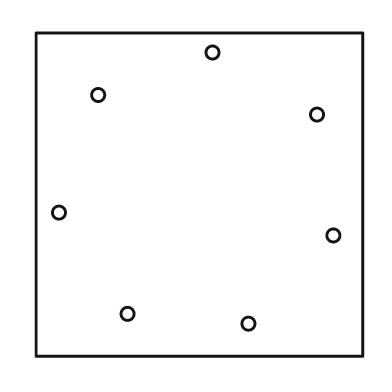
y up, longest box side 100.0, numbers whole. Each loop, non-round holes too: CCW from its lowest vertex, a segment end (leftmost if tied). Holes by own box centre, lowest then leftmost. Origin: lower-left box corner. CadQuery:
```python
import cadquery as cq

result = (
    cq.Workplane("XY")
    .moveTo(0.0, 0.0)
    .lineTo(100.0, 0.0)
    .lineTo(100.0, 99.0)
    .lineTo(0.0, 99.0)
    .close()
    .moveTo(65.0, 10.0)
    .circle(2.0)
    .moveTo(28.0, 13.0)
    .circle(2.0)
    .moveTo(91.0, 37.0)
    .circle(2.0)
    .moveTo(7.0, 44.0)
    .circle(2.0)
    .moveTo(86.0, 74.0)
    .circle(2.0)
    .moveTo(19.0, 80.0)
    .circle(2.0)
    .moveTo(54.0, 93.0)
    .circle(2.0)
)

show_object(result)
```